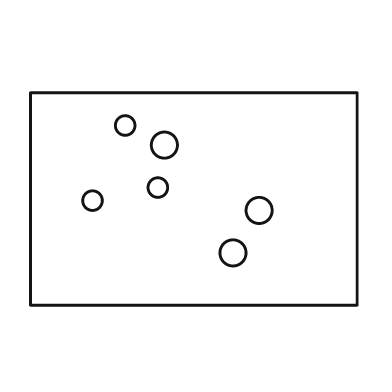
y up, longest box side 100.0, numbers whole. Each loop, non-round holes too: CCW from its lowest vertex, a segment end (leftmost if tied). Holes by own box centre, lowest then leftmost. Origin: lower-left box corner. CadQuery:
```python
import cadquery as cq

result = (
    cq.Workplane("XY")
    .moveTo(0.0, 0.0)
    .lineTo(100.0, 0.0)
    .lineTo(100.0, 65.0)
    .lineTo(0.0, 65.0)
    .close()
    .moveTo(62.0, 16.0)
    .circle(4.0)
    .moveTo(70.0, 29.0)
    .circle(4.0)
    .moveTo(19.0, 32.0)
    .circle(3.0)
    .moveTo(39.0, 36.0)
    .circle(3.0)
    .moveTo(41.0, 49.0)
    .circle(4.0)
    .moveTo(29.0, 55.0)
    .circle(3.0)
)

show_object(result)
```